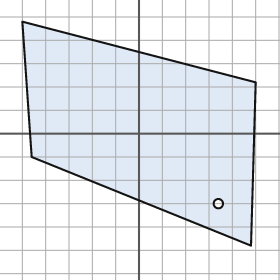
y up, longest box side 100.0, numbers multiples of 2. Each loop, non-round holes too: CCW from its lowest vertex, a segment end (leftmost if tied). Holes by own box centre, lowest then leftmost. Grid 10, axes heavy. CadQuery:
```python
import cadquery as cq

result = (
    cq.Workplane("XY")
    .moveTo(48.0, -48.0)
    .lineTo(50.0, 22.0)
    .lineTo(-50.0, 48.0)
    .lineTo(-46.0, -10.0)
    .close()
    .moveTo(34.0, -30.0)
    .circle(2.0)
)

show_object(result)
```